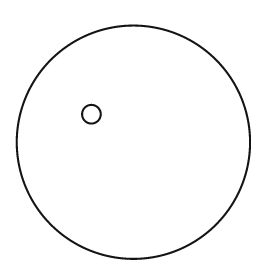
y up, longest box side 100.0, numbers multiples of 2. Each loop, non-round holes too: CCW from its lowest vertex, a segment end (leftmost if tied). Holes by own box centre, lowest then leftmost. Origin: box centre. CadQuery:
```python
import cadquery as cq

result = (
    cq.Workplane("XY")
    .moveTo(0.0, 0.0)
    .circle(50.0)
    .moveTo(-18.0, 12.0)
    .circle(4.0)
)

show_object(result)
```